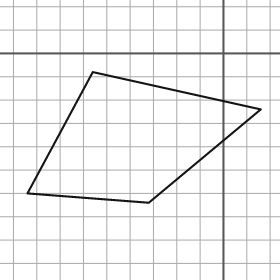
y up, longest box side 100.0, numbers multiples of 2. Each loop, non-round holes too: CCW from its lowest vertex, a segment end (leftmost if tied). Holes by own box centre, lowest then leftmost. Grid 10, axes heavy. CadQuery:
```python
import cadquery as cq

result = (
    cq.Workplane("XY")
    .moveTo(-32.0, -64.0)
    .lineTo(16.0, -24.0)
    .lineTo(-56.0, -8.0)
    .lineTo(-84.0, -60.0)
    .close()
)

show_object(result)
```